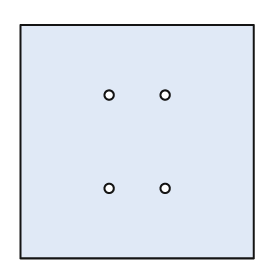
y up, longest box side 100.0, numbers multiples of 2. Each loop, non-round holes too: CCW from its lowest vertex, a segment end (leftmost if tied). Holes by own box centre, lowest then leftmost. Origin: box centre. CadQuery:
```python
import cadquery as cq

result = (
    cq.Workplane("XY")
    .moveTo(-50.0, -50.0)
    .lineTo(50.0, -50.0)
    .lineTo(50.0, 50.0)
    .lineTo(-50.0, 50.0)
    .close()
    .moveTo(-12.0, -20.0)
    .circle(2.0)
    .moveTo(12.0, -20.0)
    .circle(2.0)
    .moveTo(-12.0, 20.0)
    .circle(2.0)
    .moveTo(12.0, 20.0)
    .circle(2.0)
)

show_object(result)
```